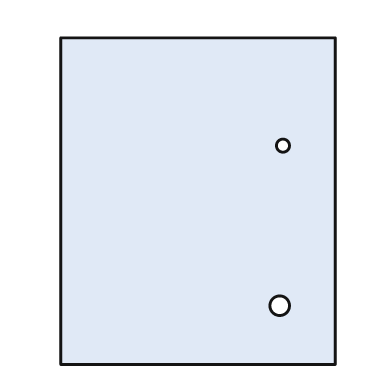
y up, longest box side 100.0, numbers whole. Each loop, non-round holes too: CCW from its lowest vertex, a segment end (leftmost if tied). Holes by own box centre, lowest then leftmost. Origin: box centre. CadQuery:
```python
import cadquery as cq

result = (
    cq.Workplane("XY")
    .moveTo(-42.0, -50.0)
    .lineTo(42.0, -50.0)
    .lineTo(42.0, 50.0)
    .lineTo(-42.0, 50.0)
    .close()
    .moveTo(25.0, -32.0)
    .circle(3.0)
    .moveTo(26.0, 17.0)
    .circle(2.0)
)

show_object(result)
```